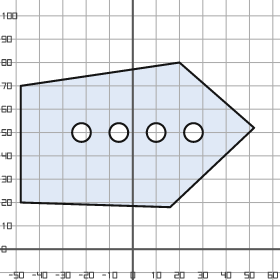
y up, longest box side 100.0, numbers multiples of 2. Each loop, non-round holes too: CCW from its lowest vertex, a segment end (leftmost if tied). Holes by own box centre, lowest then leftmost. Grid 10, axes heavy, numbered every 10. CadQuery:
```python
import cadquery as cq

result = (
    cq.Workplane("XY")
    .moveTo(16.0, 18.0)
    .lineTo(52.0, 52.0)
    .lineTo(20.0, 80.0)
    .lineTo(-48.0, 70.0)
    .lineTo(-48.0, 20.0)
    .close()
    .moveTo(-22.0, 50.0)
    .circle(4.0)
    .moveTo(-6.0, 50.0)
    .circle(4.0)
    .moveTo(10.0, 50.0)
    .circle(4.0)
    .moveTo(26.0, 50.0)
    .circle(4.0)
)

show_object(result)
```